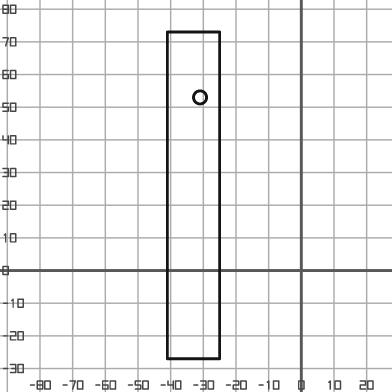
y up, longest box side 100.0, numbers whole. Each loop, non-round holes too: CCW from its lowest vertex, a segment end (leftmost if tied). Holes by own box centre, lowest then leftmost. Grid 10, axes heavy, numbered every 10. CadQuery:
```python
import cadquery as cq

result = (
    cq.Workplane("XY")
    .moveTo(-41.0, -27.0)
    .lineTo(-25.0, -27.0)
    .lineTo(-25.0, 73.0)
    .lineTo(-41.0, 73.0)
    .close()
    .moveTo(-31.0, 53.0)
    .circle(2.0)
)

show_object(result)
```